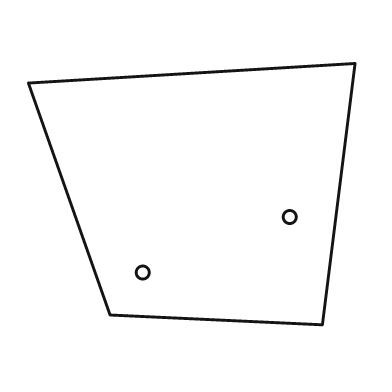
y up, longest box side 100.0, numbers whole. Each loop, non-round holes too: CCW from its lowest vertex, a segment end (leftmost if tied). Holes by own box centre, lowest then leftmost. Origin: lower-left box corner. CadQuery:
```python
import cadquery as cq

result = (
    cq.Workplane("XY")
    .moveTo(90.0, 0.0)
    .lineTo(100.0, 80.0)
    .lineTo(0.0, 74.0)
    .lineTo(25.0, 3.0)
    .close()
    .moveTo(35.0, 16.0)
    .circle(2.0)
    .moveTo(80.0, 33.0)
    .circle(2.0)
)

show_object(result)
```